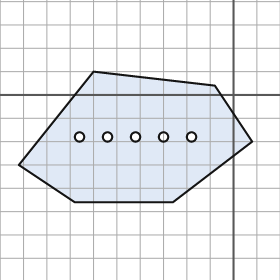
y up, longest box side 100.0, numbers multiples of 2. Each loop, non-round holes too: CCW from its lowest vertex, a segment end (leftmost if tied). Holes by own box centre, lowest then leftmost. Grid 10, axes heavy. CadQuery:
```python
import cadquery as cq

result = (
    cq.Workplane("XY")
    .moveTo(-68.0, -46.0)
    .lineTo(-26.0, -46.0)
    .lineTo(8.0, -20.0)
    .lineTo(-8.0, 4.0)
    .lineTo(-60.0, 10.0)
    .lineTo(-92.0, -30.0)
    .close()
    .moveTo(-66.0, -18.0)
    .circle(2.0)
    .moveTo(-54.0, -18.0)
    .circle(2.0)
    .moveTo(-42.0, -18.0)
    .circle(2.0)
    .moveTo(-30.0, -18.0)
    .circle(2.0)
    .moveTo(-18.0, -18.0)
    .circle(2.0)
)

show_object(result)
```